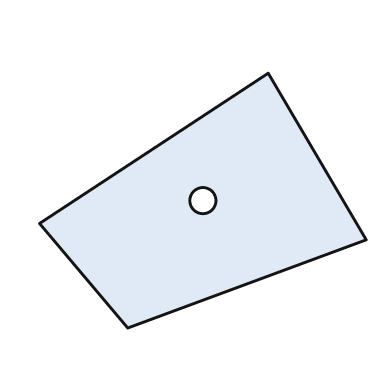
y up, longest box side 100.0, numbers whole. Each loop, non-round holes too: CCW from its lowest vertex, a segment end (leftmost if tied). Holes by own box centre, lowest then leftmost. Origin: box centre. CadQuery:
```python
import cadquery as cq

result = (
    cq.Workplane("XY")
    .moveTo(-23.0, -39.0)
    .lineTo(50.0, -12.0)
    .lineTo(20.0, 39.0)
    .lineTo(-50.0, -7.0)
    .close()
    .moveTo(0.0, 0.0)
    .circle(4.0)
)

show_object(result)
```